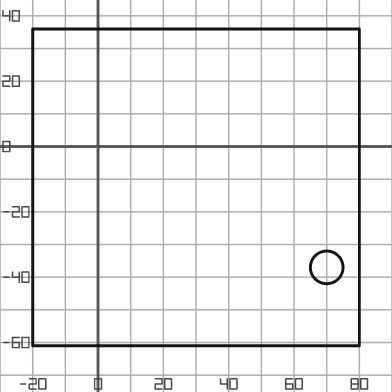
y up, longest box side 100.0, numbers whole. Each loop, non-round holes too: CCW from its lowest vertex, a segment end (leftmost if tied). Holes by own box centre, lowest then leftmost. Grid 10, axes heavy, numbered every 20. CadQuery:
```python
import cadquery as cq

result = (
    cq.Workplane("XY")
    .moveTo(-20.0, -61.0)
    .lineTo(80.0, -61.0)
    .lineTo(80.0, 36.0)
    .lineTo(-20.0, 36.0)
    .close()
    .moveTo(70.0, -37.0)
    .circle(5.0)
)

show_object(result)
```